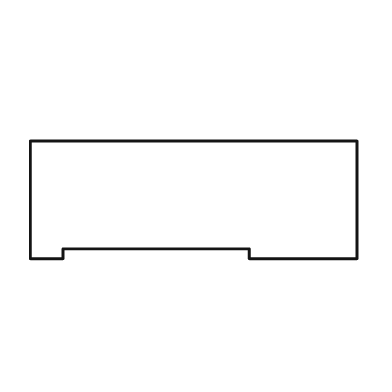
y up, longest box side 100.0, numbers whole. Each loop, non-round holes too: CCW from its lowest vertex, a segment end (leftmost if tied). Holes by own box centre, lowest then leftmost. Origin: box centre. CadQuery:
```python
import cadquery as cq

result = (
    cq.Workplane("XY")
    .moveTo(-50.0, -18.0)
    .lineTo(-40.0, -18.0)
    .lineTo(-40.0, -15.0)
    .lineTo(17.0, -15.0)
    .lineTo(17.0, -18.0)
    .lineTo(50.0, -18.0)
    .lineTo(50.0, 18.0)
    .lineTo(-50.0, 18.0)
    .close()
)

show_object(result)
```